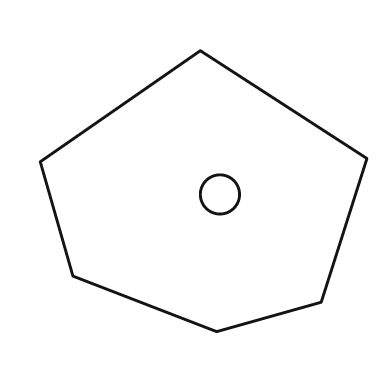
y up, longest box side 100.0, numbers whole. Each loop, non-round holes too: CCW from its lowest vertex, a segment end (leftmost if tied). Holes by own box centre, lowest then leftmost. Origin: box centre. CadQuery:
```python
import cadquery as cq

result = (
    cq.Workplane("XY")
    .moveTo(4.0, -43.0)
    .lineTo(36.0, -34.0)
    .lineTo(50.0, 10.0)
    .lineTo(-1.0, 43.0)
    .lineTo(-50.0, 9.0)
    .lineTo(-40.0, -26.0)
    .close()
    .moveTo(5.0, -1.0)
    .circle(6.0)
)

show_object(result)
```